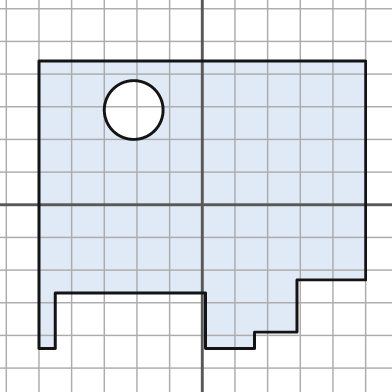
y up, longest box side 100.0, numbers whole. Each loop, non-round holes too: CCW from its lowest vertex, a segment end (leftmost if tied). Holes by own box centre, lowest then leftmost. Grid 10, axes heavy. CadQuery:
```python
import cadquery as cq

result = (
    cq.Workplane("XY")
    .moveTo(-50.0, -44.0)
    .lineTo(-45.0, -44.0)
    .lineTo(-45.0, -27.0)
    .lineTo(1.0, -27.0)
    .lineTo(1.0, -44.0)
    .lineTo(16.0, -44.0)
    .lineTo(16.0, -39.0)
    .lineTo(29.0, -39.0)
    .lineTo(29.0, -23.0)
    .lineTo(50.0, -23.0)
    .lineTo(50.0, 44.0)
    .lineTo(-50.0, 44.0)
    .close()
    .moveTo(-21.0, 29.0)
    .circle(9.0)
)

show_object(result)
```